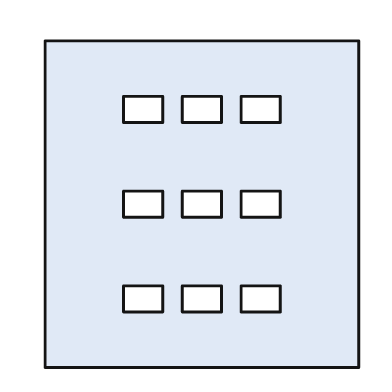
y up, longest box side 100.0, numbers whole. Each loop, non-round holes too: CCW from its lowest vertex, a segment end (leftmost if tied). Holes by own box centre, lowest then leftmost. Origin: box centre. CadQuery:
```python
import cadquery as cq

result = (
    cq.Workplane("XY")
    .moveTo(-48.0, -50.0)
    .lineTo(48.0, -50.0)
    .lineTo(48.0, 50.0)
    .lineTo(-48.0, 50.0)
    .close()
    .moveTo(-24.0, -33.0)
    .lineTo(-12.0, -33.0)
    .lineTo(-12.0, -25.0)
    .lineTo(-24.0, -25.0)
    .close()
    .moveTo(-6.0, -33.0)
    .lineTo(6.0, -33.0)
    .lineTo(6.0, -25.0)
    .lineTo(-6.0, -25.0)
    .close()
    .moveTo(12.0, -33.0)
    .lineTo(24.0, -33.0)
    .lineTo(24.0, -25.0)
    .lineTo(12.0, -25.0)
    .close()
    .moveTo(-24.0, -4.0)
    .lineTo(-12.0, -4.0)
    .lineTo(-12.0, 4.0)
    .lineTo(-24.0, 4.0)
    .close()
    .moveTo(-6.0, -4.0)
    .lineTo(6.0, -4.0)
    .lineTo(6.0, 4.0)
    .lineTo(-6.0, 4.0)
    .close()
    .moveTo(12.0, -4.0)
    .lineTo(24.0, -4.0)
    .lineTo(24.0, 4.0)
    .lineTo(12.0, 4.0)
    .close()
    .moveTo(-24.0, 25.0)
    .lineTo(-12.0, 25.0)
    .lineTo(-12.0, 33.0)
    .lineTo(-24.0, 33.0)
    .close()
    .moveTo(-6.0, 25.0)
    .lineTo(6.0, 25.0)
    .lineTo(6.0, 33.0)
    .lineTo(-6.0, 33.0)
    .close()
    .moveTo(12.0, 25.0)
    .lineTo(24.0, 25.0)
    .lineTo(24.0, 33.0)
    .lineTo(12.0, 33.0)
    .close()
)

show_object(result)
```